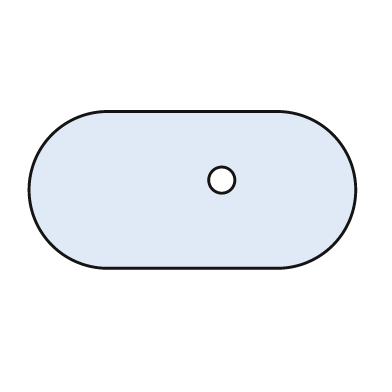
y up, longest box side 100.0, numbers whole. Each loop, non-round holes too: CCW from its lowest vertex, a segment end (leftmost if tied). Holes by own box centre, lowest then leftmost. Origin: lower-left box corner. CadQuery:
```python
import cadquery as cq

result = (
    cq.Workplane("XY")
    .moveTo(24.0, 0.0)
    .lineTo(76.0, 0.0)
    .threePointArc((100.0, 24.0), (76.0, 48.0))
    .lineTo(24.0, 48.0)
    .threePointArc((0.0, 24.0), (24.0, 0.0))
    .close()
    .moveTo(59.0, 27.0)
    .circle(4.0)
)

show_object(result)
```